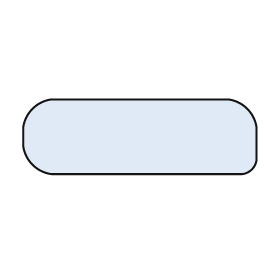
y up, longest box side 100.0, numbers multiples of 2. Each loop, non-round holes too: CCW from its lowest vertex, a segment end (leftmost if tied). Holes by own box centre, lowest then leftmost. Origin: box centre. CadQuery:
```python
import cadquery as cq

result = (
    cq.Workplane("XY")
    .moveTo(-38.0, -16.0)
    .lineTo(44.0, -16.0)
    .threePointArc((48.0, -14.0), (50.0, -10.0))
    .lineTo(50.0, 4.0)
    .threePointArc((46.0, 12.0), (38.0, 16.0))
    .lineTo(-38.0, 16.0)
    .threePointArc((-46.0, 12.0), (-50.0, 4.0))
    .lineTo(-50.0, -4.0)
    .threePointArc((-46.0, -12.0), (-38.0, -16.0))
    .close()
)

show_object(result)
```